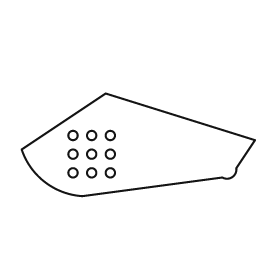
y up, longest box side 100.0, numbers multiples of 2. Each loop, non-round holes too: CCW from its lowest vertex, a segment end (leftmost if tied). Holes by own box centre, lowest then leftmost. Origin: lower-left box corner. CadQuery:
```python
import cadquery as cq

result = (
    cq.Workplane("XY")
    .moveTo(26.0, 0.0)
    .lineTo(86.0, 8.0)
    .threePointArc((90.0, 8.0), (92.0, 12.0))
    .lineTo(100.0, 24.0)
    .lineTo(36.0, 44.0)
    .lineTo(0.0, 20.0)
    .threePointArc((10.0, 6.0), (26.0, 0.0))
    .close()
    .moveTo(22.0, 10.0)
    .circle(2.0)
    .moveTo(30.0, 10.0)
    .circle(2.0)
    .moveTo(38.0, 10.0)
    .circle(2.0)
    .moveTo(22.0, 18.0)
    .circle(2.0)
    .moveTo(30.0, 18.0)
    .circle(2.0)
    .moveTo(38.0, 18.0)
    .circle(2.0)
    .moveTo(22.0, 26.0)
    .circle(2.0)
    .moveTo(30.0, 26.0)
    .circle(2.0)
    .moveTo(38.0, 26.0)
    .circle(2.0)
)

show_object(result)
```